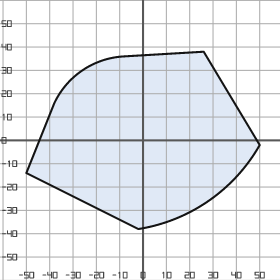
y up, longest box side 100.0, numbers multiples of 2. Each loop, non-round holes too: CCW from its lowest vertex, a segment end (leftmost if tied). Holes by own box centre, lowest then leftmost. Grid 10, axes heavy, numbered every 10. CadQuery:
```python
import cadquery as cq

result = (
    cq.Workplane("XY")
    .moveTo(-2.0, -38.0)
    .threePointArc((28.0, -26.0), (50.0, -2.0))
    .lineTo(26.0, 38.0)
    .lineTo(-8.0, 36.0)
    .threePointArc((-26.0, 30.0), (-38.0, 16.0))
    .lineTo(-50.0, -14.0)
    .close()
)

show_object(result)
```